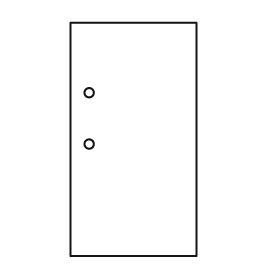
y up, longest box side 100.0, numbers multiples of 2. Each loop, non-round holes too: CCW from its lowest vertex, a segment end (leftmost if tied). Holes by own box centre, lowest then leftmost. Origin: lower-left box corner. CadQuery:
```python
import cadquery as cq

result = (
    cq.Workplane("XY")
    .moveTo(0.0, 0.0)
    .lineTo(54.0, 0.0)
    .lineTo(54.0, 100.0)
    .lineTo(0.0, 100.0)
    .close()
    .moveTo(8.0, 48.0)
    .circle(2.0)
    .moveTo(8.0, 70.0)
    .circle(2.0)
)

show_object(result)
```